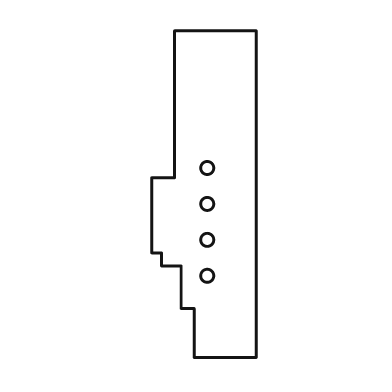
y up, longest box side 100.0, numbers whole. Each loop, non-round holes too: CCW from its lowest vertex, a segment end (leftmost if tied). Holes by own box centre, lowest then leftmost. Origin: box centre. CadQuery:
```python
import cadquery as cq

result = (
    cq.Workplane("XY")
    .moveTo(-3.0, -50.0)
    .lineTo(16.0, -50.0)
    .lineTo(16.0, 50.0)
    .lineTo(-9.0, 50.0)
    .lineTo(-9.0, 5.0)
    .lineTo(-16.0, 5.0)
    .lineTo(-16.0, -18.0)
    .lineTo(-13.0, -18.0)
    .lineTo(-13.0, -22.0)
    .lineTo(-7.0, -22.0)
    .lineTo(-7.0, -35.0)
    .lineTo(-3.0, -35.0)
    .close()
    .moveTo(1.0, -25.0)
    .circle(2.0)
    .moveTo(1.0, -14.0)
    .circle(2.0)
    .moveTo(1.0, -3.0)
    .circle(2.0)
    .moveTo(1.0, 8.0)
    .circle(2.0)
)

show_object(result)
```